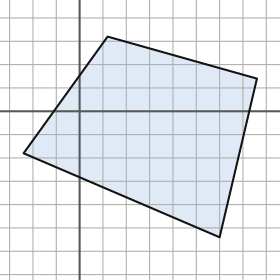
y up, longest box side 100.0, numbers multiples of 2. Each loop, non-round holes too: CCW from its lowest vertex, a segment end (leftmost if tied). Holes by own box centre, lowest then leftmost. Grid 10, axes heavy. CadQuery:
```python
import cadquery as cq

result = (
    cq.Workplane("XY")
    .moveTo(60.0, -54.0)
    .lineTo(76.0, 14.0)
    .lineTo(12.0, 32.0)
    .lineTo(-24.0, -18.0)
    .close()
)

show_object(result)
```